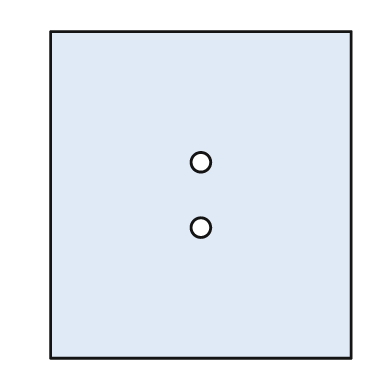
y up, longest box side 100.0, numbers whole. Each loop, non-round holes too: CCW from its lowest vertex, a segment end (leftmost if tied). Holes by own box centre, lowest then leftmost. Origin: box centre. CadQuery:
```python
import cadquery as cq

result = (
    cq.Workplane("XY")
    .moveTo(-46.0, -50.0)
    .lineTo(46.0, -50.0)
    .lineTo(46.0, 50.0)
    .lineTo(-46.0, 50.0)
    .close()
    .moveTo(0.0, -10.0)
    .circle(3.0)
    .moveTo(0.0, 10.0)
    .circle(3.0)
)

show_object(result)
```